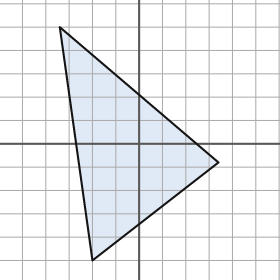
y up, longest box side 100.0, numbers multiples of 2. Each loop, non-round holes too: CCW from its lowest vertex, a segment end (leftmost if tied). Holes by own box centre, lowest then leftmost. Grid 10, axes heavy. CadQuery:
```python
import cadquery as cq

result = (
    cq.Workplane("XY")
    .moveTo(-20.0, -50.0)
    .lineTo(34.0, -8.0)
    .lineTo(-34.0, 50.0)
    .close()
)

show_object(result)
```